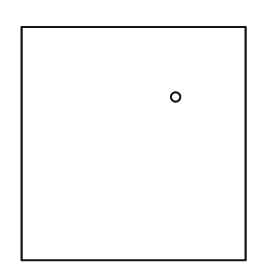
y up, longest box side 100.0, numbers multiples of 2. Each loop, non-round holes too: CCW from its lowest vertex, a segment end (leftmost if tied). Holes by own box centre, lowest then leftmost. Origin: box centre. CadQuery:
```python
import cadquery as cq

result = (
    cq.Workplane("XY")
    .moveTo(-48.0, -50.0)
    .lineTo(48.0, -50.0)
    .lineTo(48.0, 50.0)
    .lineTo(-48.0, 50.0)
    .close()
    .moveTo(18.0, 20.0)
    .circle(2.0)
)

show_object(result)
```